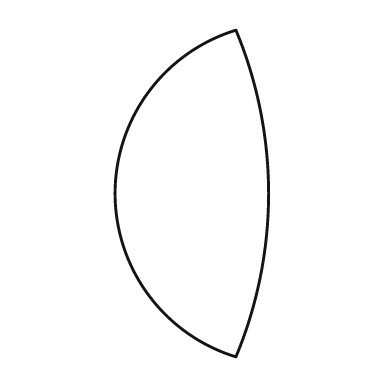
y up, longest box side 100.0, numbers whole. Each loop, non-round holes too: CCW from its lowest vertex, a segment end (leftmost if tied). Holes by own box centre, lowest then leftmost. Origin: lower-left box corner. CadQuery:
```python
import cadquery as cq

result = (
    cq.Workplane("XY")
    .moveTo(37.0, 0.0)
    .threePointArc((47.0, 50.0), (37.0, 100.0))
    .threePointArc((0.0, 50.0), (37.0, 0.0))
    .close()
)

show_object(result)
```